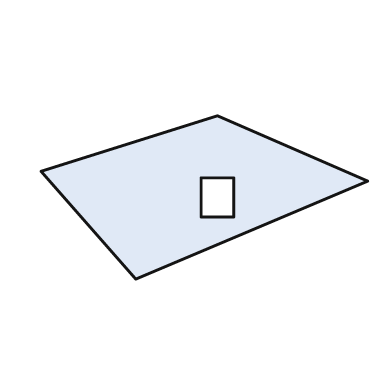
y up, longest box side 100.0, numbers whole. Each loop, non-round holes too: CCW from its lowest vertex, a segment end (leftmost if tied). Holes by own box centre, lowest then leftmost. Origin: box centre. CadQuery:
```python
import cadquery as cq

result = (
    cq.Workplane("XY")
    .moveTo(-21.0, -25.0)
    .lineTo(50.0, 5.0)
    .lineTo(4.0, 25.0)
    .lineTo(-50.0, 8.0)
    .close()
    .moveTo(-1.0, -6.0)
    .lineTo(9.0, -6.0)
    .lineTo(9.0, 6.0)
    .lineTo(-1.0, 6.0)
    .close()
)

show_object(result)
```